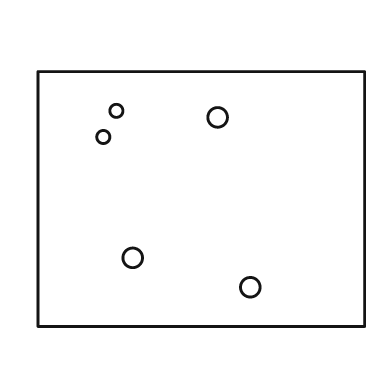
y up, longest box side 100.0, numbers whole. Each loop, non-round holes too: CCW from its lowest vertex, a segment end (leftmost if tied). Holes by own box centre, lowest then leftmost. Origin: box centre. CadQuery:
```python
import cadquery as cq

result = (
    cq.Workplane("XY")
    .moveTo(-50.0, -39.0)
    .lineTo(50.0, -39.0)
    .lineTo(50.0, 39.0)
    .lineTo(-50.0, 39.0)
    .close()
    .moveTo(15.0, -27.0)
    .circle(3.0)
    .moveTo(-21.0, -18.0)
    .circle(3.0)
    .moveTo(-30.0, 19.0)
    .circle(2.0)
    .moveTo(5.0, 25.0)
    .circle(3.0)
    .moveTo(-26.0, 27.0)
    .circle(2.0)
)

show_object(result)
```